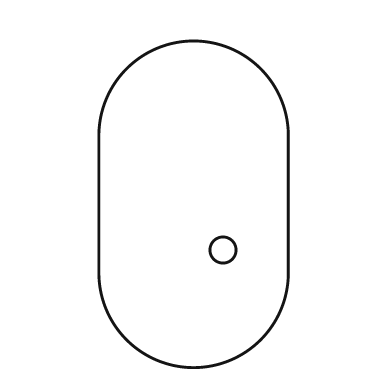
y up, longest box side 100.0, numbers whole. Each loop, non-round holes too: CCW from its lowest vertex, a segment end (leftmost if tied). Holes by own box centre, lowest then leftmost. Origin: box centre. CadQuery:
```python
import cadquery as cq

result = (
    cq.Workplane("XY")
    .moveTo(-29.0, -21.0)
    .threePointArc((0.0, -50.0), (29.0, -21.0))
    .lineTo(29.0, 21.0)
    .threePointArc((0.0, 50.0), (-29.0, 21.0))
    .close()
    .moveTo(9.0, -14.0)
    .circle(4.0)
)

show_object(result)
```